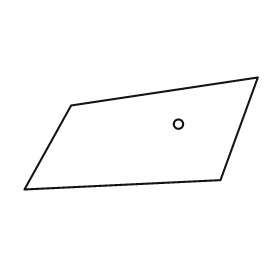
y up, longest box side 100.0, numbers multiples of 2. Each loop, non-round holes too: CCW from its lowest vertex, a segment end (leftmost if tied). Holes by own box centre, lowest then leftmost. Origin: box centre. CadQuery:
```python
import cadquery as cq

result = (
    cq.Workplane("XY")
    .moveTo(-50.0, -24.0)
    .lineTo(34.0, -20.0)
    .lineTo(50.0, 24.0)
    .lineTo(-30.0, 12.0)
    .close()
    .moveTo(16.0, 4.0)
    .circle(2.0)
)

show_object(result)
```